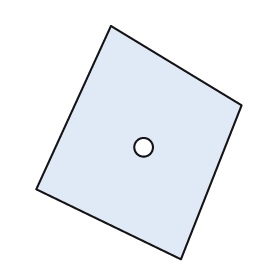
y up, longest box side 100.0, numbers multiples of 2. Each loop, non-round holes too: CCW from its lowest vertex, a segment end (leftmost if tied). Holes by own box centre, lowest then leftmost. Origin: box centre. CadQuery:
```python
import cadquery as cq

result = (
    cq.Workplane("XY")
    .moveTo(18.0, -50.0)
    .lineTo(44.0, 16.0)
    .lineTo(-12.0, 50.0)
    .lineTo(-44.0, -20.0)
    .close()
    .moveTo(2.0, -2.0)
    .circle(4.0)
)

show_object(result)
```